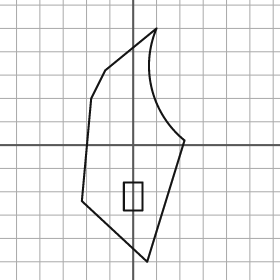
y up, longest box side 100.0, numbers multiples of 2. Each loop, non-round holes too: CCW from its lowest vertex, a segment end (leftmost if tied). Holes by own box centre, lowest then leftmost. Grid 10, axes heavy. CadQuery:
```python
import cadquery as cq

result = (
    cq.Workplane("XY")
    .moveTo(6.0, -50.0)
    .lineTo(22.0, 2.0)
    .threePointArc((8.0, 24.0), (10.0, 50.0))
    .lineTo(-12.0, 32.0)
    .lineTo(-18.0, 20.0)
    .lineTo(-22.0, -24.0)
    .close()
    .moveTo(-4.0, -28.0)
    .lineTo(4.0, -28.0)
    .lineTo(4.0, -16.0)
    .lineTo(-4.0, -16.0)
    .close()
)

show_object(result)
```